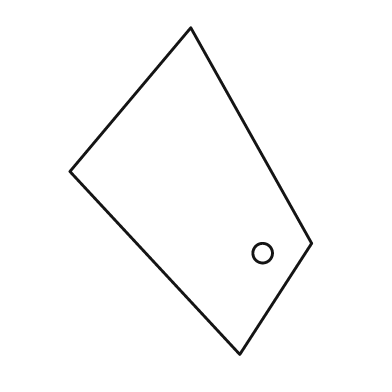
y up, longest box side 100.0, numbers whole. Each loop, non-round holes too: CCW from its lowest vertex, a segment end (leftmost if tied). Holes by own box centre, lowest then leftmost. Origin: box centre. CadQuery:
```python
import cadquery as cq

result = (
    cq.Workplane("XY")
    .moveTo(15.0, -50.0)
    .lineTo(37.0, -16.0)
    .lineTo(0.0, 50.0)
    .lineTo(-37.0, 6.0)
    .close()
    .moveTo(22.0, -19.0)
    .circle(3.0)
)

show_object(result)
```